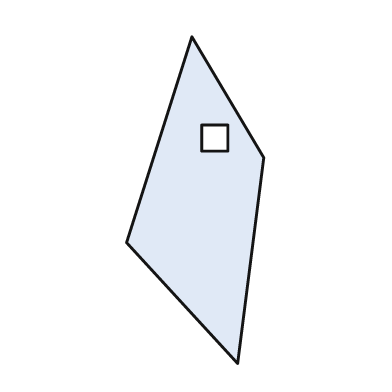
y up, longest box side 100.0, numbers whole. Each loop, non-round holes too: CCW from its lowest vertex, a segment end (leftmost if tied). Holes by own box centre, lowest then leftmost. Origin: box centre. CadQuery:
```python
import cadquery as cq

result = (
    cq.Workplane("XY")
    .moveTo(13.0, -50.0)
    .lineTo(21.0, 13.0)
    .lineTo(-1.0, 50.0)
    .lineTo(-21.0, -13.0)
    .close()
    .moveTo(2.0, 15.0)
    .lineTo(10.0, 15.0)
    .lineTo(10.0, 23.0)
    .lineTo(2.0, 23.0)
    .close()
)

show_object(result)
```